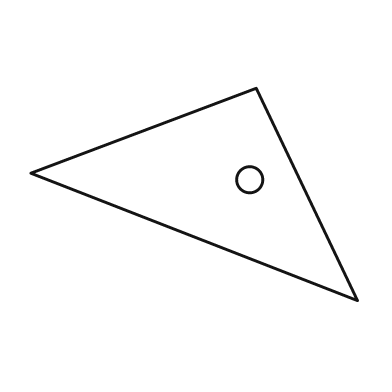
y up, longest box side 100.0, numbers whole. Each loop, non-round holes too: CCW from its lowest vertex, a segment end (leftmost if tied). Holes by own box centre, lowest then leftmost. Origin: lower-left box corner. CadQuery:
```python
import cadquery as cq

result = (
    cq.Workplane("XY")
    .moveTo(100.0, 0.0)
    .lineTo(69.0, 65.0)
    .lineTo(0.0, 39.0)
    .close()
    .moveTo(67.0, 37.0)
    .circle(4.0)
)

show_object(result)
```